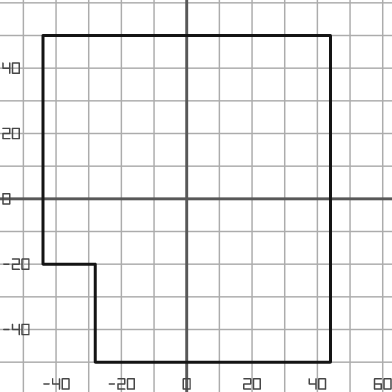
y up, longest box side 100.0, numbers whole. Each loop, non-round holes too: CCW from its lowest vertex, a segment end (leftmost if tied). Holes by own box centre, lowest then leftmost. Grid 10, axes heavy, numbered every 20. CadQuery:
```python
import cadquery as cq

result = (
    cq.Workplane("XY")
    .moveTo(-28.0, -50.0)
    .lineTo(44.0, -50.0)
    .lineTo(44.0, 50.0)
    .lineTo(-44.0, 50.0)
    .lineTo(-44.0, -20.0)
    .lineTo(-28.0, -20.0)
    .close()
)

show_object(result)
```